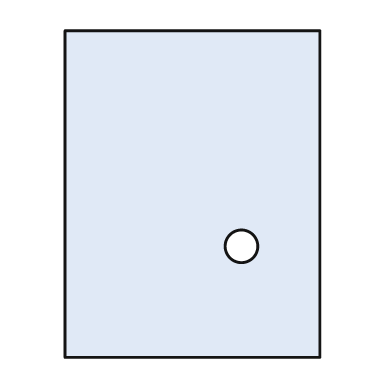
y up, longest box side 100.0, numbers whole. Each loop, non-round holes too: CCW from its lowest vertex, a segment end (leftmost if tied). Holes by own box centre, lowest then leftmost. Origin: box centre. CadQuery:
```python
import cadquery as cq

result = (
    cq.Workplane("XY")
    .moveTo(-39.0, -50.0)
    .lineTo(39.0, -50.0)
    .lineTo(39.0, 50.0)
    .lineTo(-39.0, 50.0)
    .close()
    .moveTo(15.0, -16.0)
    .circle(5.0)
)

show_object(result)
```